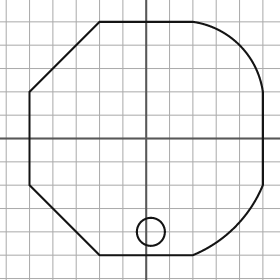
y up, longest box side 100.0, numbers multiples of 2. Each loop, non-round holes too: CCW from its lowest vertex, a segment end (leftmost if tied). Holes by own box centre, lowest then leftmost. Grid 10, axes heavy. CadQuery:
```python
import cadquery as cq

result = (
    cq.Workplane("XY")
    .moveTo(-20.0, -50.0)
    .lineTo(20.0, -50.0)
    .threePointArc((38.0, -38.0), (50.0, -20.0))
    .lineTo(50.0, 20.0)
    .threePointArc((40.0, 40.0), (20.0, 50.0))
    .lineTo(-20.0, 50.0)
    .lineTo(-50.0, 20.0)
    .lineTo(-50.0, -20.0)
    .close()
    .moveTo(2.0, -40.0)
    .circle(6.0)
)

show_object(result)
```